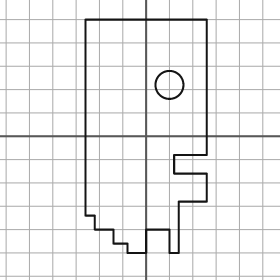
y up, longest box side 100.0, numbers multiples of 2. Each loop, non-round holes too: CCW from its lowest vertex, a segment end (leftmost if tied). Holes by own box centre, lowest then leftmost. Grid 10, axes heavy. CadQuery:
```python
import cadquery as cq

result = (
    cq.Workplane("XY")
    .moveTo(-8.0, -50.0)
    .lineTo(0.0, -50.0)
    .lineTo(0.0, -40.0)
    .lineTo(10.0, -40.0)
    .lineTo(10.0, -50.0)
    .lineTo(14.0, -50.0)
    .lineTo(14.0, -28.0)
    .lineTo(26.0, -28.0)
    .lineTo(26.0, -16.0)
    .lineTo(12.0, -16.0)
    .lineTo(12.0, -8.0)
    .lineTo(26.0, -8.0)
    .lineTo(26.0, 50.0)
    .lineTo(-26.0, 50.0)
    .lineTo(-26.0, -34.0)
    .lineTo(-22.0, -34.0)
    .lineTo(-22.0, -40.0)
    .lineTo(-14.0, -40.0)
    .lineTo(-14.0, -46.0)
    .lineTo(-8.0, -46.0)
    .close()
    .moveTo(10.0, 22.0)
    .circle(6.0)
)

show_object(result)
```